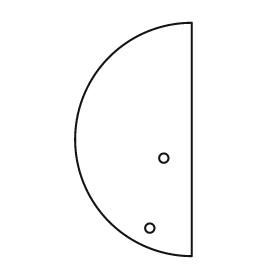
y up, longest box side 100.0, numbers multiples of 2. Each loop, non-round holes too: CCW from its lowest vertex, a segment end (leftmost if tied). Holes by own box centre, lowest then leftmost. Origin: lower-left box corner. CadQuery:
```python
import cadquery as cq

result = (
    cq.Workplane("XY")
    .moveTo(50.0, 0.0)
    .lineTo(50.0, 100.0)
    .threePointArc((0.0, 50.0), (50.0, 0.0))
    .close()
    .moveTo(32.0, 12.0)
    .circle(2.0)
    .moveTo(38.0, 42.0)
    .circle(2.0)
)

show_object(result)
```